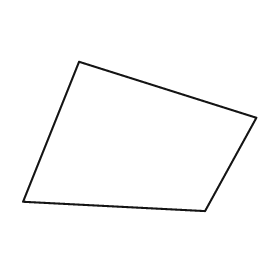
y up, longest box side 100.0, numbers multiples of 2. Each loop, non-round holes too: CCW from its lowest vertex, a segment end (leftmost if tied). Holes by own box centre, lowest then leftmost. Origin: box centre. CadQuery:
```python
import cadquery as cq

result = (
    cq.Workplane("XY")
    .moveTo(28.0, -32.0)
    .lineTo(50.0, 8.0)
    .lineTo(-26.0, 32.0)
    .lineTo(-50.0, -28.0)
    .close()
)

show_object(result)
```